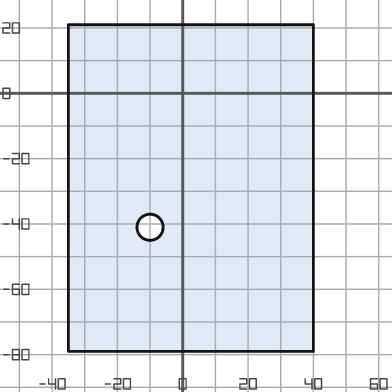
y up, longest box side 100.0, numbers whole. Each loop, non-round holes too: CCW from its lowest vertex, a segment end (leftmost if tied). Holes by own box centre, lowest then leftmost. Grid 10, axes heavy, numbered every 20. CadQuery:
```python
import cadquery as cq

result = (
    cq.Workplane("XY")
    .moveTo(-35.0, -79.0)
    .lineTo(40.0, -79.0)
    .lineTo(40.0, 21.0)
    .lineTo(-35.0, 21.0)
    .close()
    .moveTo(-10.0, -41.0)
    .circle(4.0)
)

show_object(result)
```